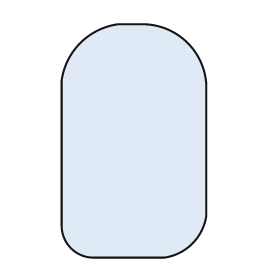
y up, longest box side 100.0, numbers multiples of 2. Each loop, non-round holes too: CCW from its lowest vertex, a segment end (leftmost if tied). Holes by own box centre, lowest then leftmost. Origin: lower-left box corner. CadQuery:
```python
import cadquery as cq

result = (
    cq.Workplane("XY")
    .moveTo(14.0, 0.0)
    .lineTo(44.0, 0.0)
    .threePointArc((56.0, 6.0), (62.0, 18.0))
    .lineTo(62.0, 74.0)
    .threePointArc((54.0, 92.0), (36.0, 100.0))
    .lineTo(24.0, 100.0)
    .threePointArc((8.0, 92.0), (0.0, 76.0))
    .lineTo(0.0, 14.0)
    .threePointArc((4.0, 4.0), (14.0, 0.0))
    .close()
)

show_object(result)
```